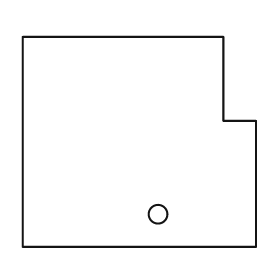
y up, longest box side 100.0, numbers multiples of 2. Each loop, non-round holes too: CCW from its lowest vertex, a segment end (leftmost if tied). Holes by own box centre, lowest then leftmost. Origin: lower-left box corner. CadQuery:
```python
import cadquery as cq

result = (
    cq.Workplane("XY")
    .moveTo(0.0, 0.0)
    .lineTo(100.0, 0.0)
    .lineTo(100.0, 54.0)
    .lineTo(86.0, 54.0)
    .lineTo(86.0, 90.0)
    .lineTo(0.0, 90.0)
    .close()
    .moveTo(58.0, 14.0)
    .circle(4.0)
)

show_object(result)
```